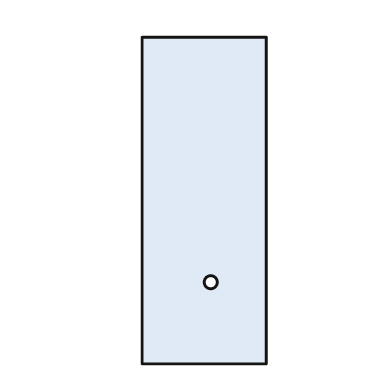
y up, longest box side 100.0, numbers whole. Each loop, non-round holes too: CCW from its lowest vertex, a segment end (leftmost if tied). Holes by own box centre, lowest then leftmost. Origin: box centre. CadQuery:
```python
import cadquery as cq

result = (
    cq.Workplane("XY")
    .moveTo(-19.0, -50.0)
    .lineTo(19.0, -50.0)
    .lineTo(19.0, 50.0)
    .lineTo(-19.0, 50.0)
    .close()
    .moveTo(2.0, -25.0)
    .circle(2.0)
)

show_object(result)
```